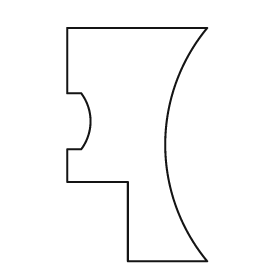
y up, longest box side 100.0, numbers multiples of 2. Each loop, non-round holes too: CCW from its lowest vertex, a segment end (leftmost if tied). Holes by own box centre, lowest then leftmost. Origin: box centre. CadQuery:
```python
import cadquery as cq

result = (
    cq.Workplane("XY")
    .moveTo(-4.0, -50.0)
    .lineTo(30.0, -50.0)
    .threePointArc((12.0, 0.0), (30.0, 50.0))
    .lineTo(-30.0, 50.0)
    .lineTo(-30.0, 22.0)
    .lineTo(-24.0, 22.0)
    .threePointArc((-20.0, 10.0), (-24.0, -2.0))
    .lineTo(-30.0, -2.0)
    .lineTo(-30.0, -16.0)
    .lineTo(-4.0, -16.0)
    .close()
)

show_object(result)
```